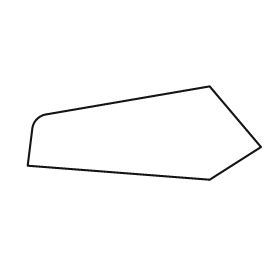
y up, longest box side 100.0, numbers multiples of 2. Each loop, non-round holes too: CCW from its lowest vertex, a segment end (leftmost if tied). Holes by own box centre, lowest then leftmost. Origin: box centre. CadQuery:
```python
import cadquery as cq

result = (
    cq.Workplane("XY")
    .moveTo(28.0, -20.0)
    .lineTo(50.0, -6.0)
    .lineTo(28.0, 20.0)
    .lineTo(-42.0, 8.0)
    .threePointArc((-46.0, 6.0), (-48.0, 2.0))
    .lineTo(-50.0, -14.0)
    .close()
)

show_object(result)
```